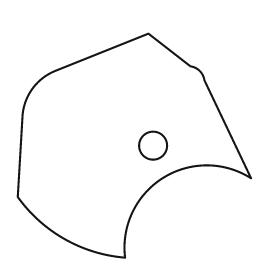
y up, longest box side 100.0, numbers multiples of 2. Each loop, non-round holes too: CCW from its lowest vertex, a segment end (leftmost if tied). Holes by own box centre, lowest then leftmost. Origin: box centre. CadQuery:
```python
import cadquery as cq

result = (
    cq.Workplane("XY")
    .moveTo(-4.0, -48.0)
    .threePointArc((12.0, -14.0), (50.0, -14.0))
    .lineTo(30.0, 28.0)
    .threePointArc((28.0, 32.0), (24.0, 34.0))
    .lineTo(6.0, 48.0)
    .lineTo(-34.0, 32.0)
    .threePointArc((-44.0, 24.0), (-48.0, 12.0))
    .lineTo(-50.0, -22.0)
    .threePointArc((-30.0, -40.0), (-4.0, -48.0))
    .close()
    .moveTo(8.0, 0.0)
    .circle(6.0)
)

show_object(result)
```